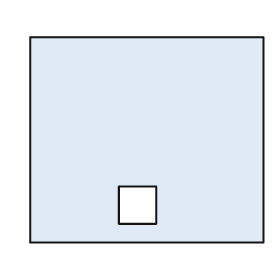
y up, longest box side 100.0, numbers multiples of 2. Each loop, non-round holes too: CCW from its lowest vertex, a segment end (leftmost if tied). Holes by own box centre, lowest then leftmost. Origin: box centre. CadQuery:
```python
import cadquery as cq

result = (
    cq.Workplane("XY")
    .moveTo(-50.0, -44.0)
    .lineTo(50.0, -44.0)
    .lineTo(50.0, 44.0)
    .lineTo(-50.0, 44.0)
    .close()
    .moveTo(-12.0, -36.0)
    .lineTo(4.0, -36.0)
    .lineTo(4.0, -20.0)
    .lineTo(-12.0, -20.0)
    .close()
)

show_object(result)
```